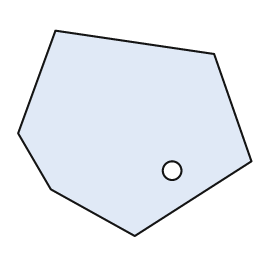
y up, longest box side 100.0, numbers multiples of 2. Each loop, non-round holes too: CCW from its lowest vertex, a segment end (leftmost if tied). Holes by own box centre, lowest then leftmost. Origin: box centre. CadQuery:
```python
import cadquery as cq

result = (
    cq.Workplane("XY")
    .moveTo(0.0, -44.0)
    .lineTo(50.0, -12.0)
    .lineTo(34.0, 34.0)
    .lineTo(-34.0, 44.0)
    .lineTo(-50.0, 0.0)
    .lineTo(-36.0, -24.0)
    .close()
    .moveTo(16.0, -16.0)
    .circle(4.0)
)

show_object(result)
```